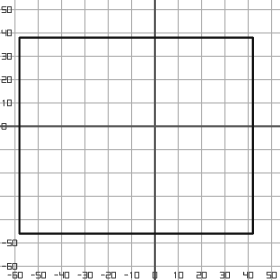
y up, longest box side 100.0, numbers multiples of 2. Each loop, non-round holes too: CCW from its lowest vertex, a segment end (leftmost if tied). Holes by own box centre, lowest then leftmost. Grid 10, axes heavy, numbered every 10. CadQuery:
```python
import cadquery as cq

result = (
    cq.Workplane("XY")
    .moveTo(-58.0, -46.0)
    .lineTo(42.0, -46.0)
    .lineTo(42.0, 38.0)
    .lineTo(-58.0, 38.0)
    .close()
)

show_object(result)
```